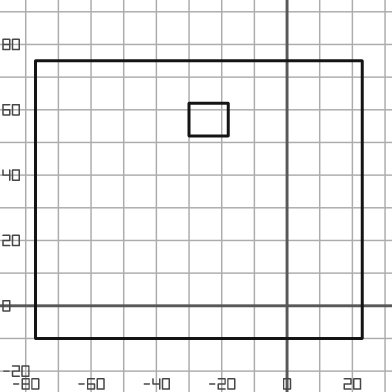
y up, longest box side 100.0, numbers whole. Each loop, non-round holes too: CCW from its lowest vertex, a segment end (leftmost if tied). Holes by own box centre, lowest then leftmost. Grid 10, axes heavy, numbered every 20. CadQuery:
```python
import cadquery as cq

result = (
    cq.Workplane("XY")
    .moveTo(-77.0, -10.0)
    .lineTo(23.0, -10.0)
    .lineTo(23.0, 75.0)
    .lineTo(-77.0, 75.0)
    .close()
    .moveTo(-30.0, 52.0)
    .lineTo(-18.0, 52.0)
    .lineTo(-18.0, 62.0)
    .lineTo(-30.0, 62.0)
    .close()
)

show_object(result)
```